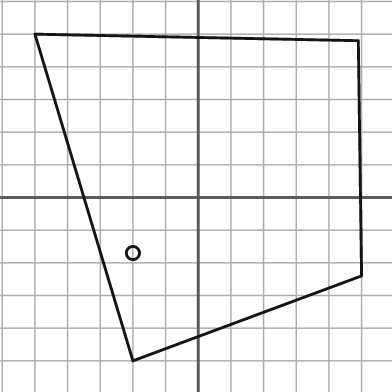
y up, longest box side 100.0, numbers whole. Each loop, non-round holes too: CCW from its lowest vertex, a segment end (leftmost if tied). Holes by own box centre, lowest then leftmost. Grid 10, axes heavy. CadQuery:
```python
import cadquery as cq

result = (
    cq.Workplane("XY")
    .moveTo(-20.0, -50.0)
    .lineTo(50.0, -24.0)
    .lineTo(49.0, 48.0)
    .lineTo(-50.0, 50.0)
    .close()
    .moveTo(-20.0, -17.0)
    .circle(2.0)
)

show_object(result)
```